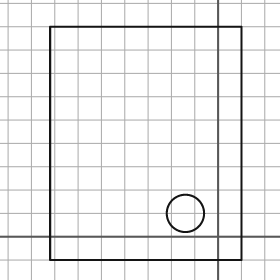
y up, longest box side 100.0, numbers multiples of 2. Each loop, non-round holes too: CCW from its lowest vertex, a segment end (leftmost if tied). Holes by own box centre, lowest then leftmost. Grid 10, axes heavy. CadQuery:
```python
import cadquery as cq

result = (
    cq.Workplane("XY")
    .moveTo(-72.0, -10.0)
    .lineTo(10.0, -10.0)
    .lineTo(10.0, 90.0)
    .lineTo(-72.0, 90.0)
    .close()
    .moveTo(-14.0, 10.0)
    .circle(8.0)
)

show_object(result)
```